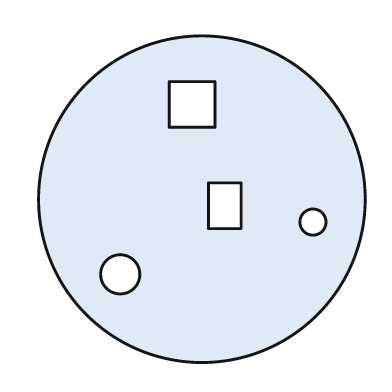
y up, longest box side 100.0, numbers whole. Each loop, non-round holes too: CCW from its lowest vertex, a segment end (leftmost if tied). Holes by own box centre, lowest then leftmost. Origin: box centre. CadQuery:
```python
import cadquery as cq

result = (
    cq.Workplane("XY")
    .moveTo(0.0, 0.0)
    .circle(50.0)
    .moveTo(-25.0, -23.0)
    .circle(6.0)
    .moveTo(34.0, -7.0)
    .circle(4.0)
    .moveTo(2.0, -9.0)
    .lineTo(12.0, -9.0)
    .lineTo(12.0, 5.0)
    .lineTo(2.0, 5.0)
    .close()
    .moveTo(-10.0, 22.0)
    .lineTo(4.0, 22.0)
    .lineTo(4.0, 36.0)
    .lineTo(-10.0, 36.0)
    .close()
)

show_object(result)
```